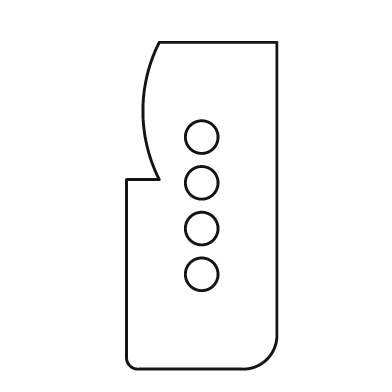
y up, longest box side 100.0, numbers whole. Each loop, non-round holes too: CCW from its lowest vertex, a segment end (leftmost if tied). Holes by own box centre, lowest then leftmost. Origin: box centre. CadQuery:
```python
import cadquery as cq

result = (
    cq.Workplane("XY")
    .moveTo(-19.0, -50.0)
    .lineTo(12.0, -50.0)
    .threePointArc((20.0, -47.0), (23.0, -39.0))
    .lineTo(23.0, 50.0)
    .lineTo(-13.0, 50.0)
    .threePointArc((-18.0, 29.0), (-13.0, 8.0))
    .lineTo(-23.0, 8.0)
    .lineTo(-23.0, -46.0)
    .threePointArc((-22.0, -49.0), (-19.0, -50.0))
    .close()
    .moveTo(0.0, -21.0)
    .circle(5.0)
    .moveTo(0.0, -7.0)
    .circle(5.0)
    .moveTo(0.0, 7.0)
    .circle(5.0)
    .moveTo(0.0, 21.0)
    .circle(5.0)
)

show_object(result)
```